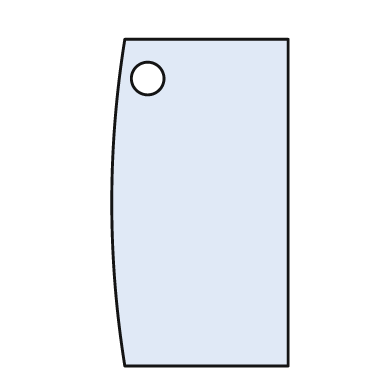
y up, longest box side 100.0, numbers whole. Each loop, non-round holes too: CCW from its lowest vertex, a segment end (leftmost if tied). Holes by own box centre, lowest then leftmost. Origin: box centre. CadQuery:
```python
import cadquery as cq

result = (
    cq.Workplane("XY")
    .moveTo(-23.0, -50.0)
    .lineTo(27.0, -50.0)
    .lineTo(27.0, 50.0)
    .lineTo(-23.0, 50.0)
    .threePointArc((-27.0, 0.0), (-23.0, -50.0))
    .close()
    .moveTo(-16.0, 38.0)
    .circle(5.0)
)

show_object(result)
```